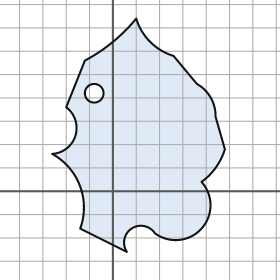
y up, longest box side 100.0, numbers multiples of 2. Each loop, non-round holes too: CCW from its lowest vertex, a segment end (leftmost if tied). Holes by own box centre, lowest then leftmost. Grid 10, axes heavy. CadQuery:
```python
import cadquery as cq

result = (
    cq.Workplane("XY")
    .moveTo(6.0, -26.0)
    .threePointArc((8.0, -16.0), (18.0, -18.0))
    .threePointArc((38.0, -16.0), (38.0, 4.0))
    .threePointArc((44.0, 10.0), (48.0, 18.0))
    .lineTo(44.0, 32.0)
    .threePointArc((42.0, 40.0), (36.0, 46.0))
    .lineTo(26.0, 58.0)
    .threePointArc((16.0, 64.0), (10.0, 74.0))
    .threePointArc((0.0, 64.0), (-12.0, 56.0))
    .lineTo(-20.0, 36.0)
    .threePointArc((-16.0, 24.0), (-26.0, 16.0))
    .threePointArc((-14.0, 2.0), (-14.0, -16.0))
    .close()
    .moveTo(-8.0, 42.0)
    .circle(4.0)
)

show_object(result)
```